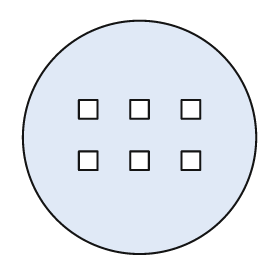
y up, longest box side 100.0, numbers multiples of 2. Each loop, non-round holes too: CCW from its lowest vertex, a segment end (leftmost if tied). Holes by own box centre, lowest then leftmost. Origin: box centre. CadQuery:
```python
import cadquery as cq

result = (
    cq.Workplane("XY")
    .moveTo(0.0, 0.0)
    .circle(50.0)
    .moveTo(-26.0, -14.0)
    .lineTo(-18.0, -14.0)
    .lineTo(-18.0, -6.0)
    .lineTo(-26.0, -6.0)
    .close()
    .moveTo(-4.0, -14.0)
    .lineTo(4.0, -14.0)
    .lineTo(4.0, -6.0)
    .lineTo(-4.0, -6.0)
    .close()
    .moveTo(18.0, -14.0)
    .lineTo(26.0, -14.0)
    .lineTo(26.0, -6.0)
    .lineTo(18.0, -6.0)
    .close()
    .moveTo(-26.0, 8.0)
    .lineTo(-18.0, 8.0)
    .lineTo(-18.0, 16.0)
    .lineTo(-26.0, 16.0)
    .close()
    .moveTo(-4.0, 8.0)
    .lineTo(4.0, 8.0)
    .lineTo(4.0, 16.0)
    .lineTo(-4.0, 16.0)
    .close()
    .moveTo(18.0, 8.0)
    .lineTo(26.0, 8.0)
    .lineTo(26.0, 16.0)
    .lineTo(18.0, 16.0)
    .close()
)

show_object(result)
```